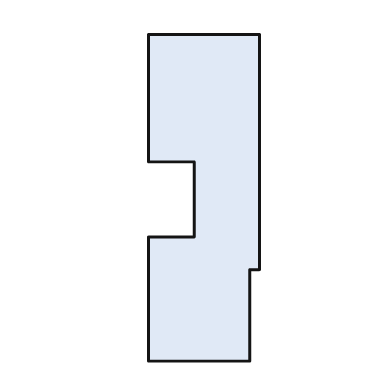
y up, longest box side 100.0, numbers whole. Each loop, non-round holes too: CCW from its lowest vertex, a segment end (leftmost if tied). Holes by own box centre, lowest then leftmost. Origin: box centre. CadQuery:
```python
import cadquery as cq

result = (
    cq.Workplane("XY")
    .moveTo(-17.0, -50.0)
    .lineTo(14.0, -50.0)
    .lineTo(14.0, -22.0)
    .lineTo(17.0, -22.0)
    .lineTo(17.0, 50.0)
    .lineTo(-17.0, 50.0)
    .lineTo(-17.0, 11.0)
    .lineTo(-3.0, 11.0)
    .lineTo(-3.0, -12.0)
    .lineTo(-17.0, -12.0)
    .close()
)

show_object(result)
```